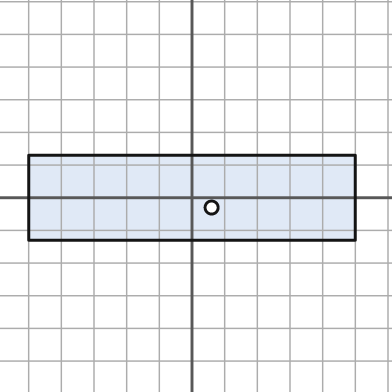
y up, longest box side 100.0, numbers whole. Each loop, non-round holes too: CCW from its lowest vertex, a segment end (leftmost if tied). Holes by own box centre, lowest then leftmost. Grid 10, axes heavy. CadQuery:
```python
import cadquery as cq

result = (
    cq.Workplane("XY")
    .moveTo(-50.0, -13.0)
    .lineTo(50.0, -13.0)
    .lineTo(50.0, 13.0)
    .lineTo(-50.0, 13.0)
    .close()
    .moveTo(6.0, -3.0)
    .circle(2.0)
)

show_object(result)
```